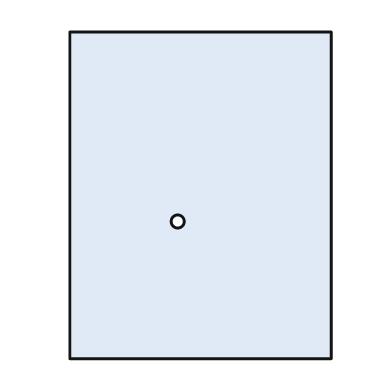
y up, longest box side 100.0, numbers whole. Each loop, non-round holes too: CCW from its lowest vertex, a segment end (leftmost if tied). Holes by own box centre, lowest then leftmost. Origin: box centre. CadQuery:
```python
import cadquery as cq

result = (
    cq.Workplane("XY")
    .moveTo(-40.0, -50.0)
    .lineTo(40.0, -50.0)
    .lineTo(40.0, 50.0)
    .lineTo(-40.0, 50.0)
    .close()
    .moveTo(-7.0, -8.0)
    .circle(2.0)
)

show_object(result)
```